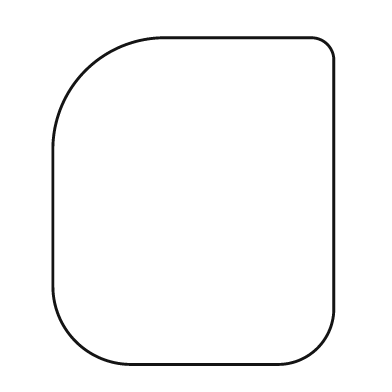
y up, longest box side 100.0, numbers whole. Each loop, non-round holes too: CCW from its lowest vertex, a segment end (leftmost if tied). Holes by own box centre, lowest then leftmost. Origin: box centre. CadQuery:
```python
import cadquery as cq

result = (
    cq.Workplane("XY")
    .moveTo(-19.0, -50.0)
    .lineTo(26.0, -50.0)
    .threePointArc((38.0, -45.0), (43.0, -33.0))
    .lineTo(43.0, 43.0)
    .threePointArc((41.0, 48.0), (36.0, 50.0))
    .lineTo(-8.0, 50.0)
    .threePointArc((-33.0, 40.0), (-43.0, 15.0))
    .lineTo(-43.0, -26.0)
    .threePointArc((-36.0, -43.0), (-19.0, -50.0))
    .close()
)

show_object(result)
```